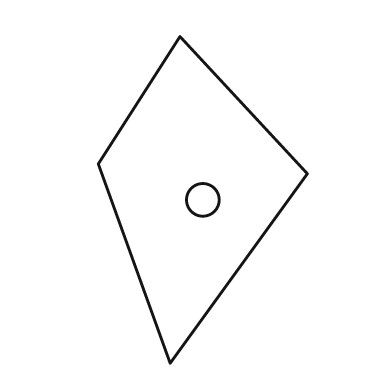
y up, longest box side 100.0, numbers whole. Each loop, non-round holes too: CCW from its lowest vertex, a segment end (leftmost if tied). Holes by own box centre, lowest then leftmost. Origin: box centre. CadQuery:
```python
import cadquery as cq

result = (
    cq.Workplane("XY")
    .moveTo(-10.0, -50.0)
    .lineTo(32.0, 8.0)
    .lineTo(-7.0, 50.0)
    .lineTo(-32.0, 11.0)
    .close()
    .moveTo(0.0, 0.0)
    .circle(5.0)
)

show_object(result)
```